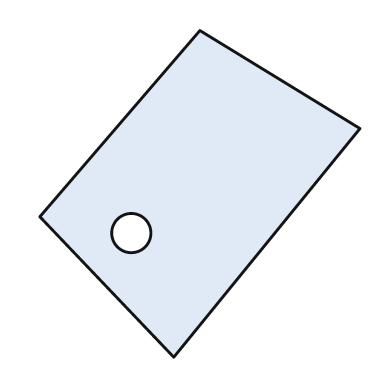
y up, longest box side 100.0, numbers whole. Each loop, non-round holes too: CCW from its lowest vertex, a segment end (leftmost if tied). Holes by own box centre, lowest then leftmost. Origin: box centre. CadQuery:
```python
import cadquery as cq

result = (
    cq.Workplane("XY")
    .moveTo(-8.0, -50.0)
    .lineTo(49.0, 20.0)
    .lineTo(0.0, 50.0)
    .lineTo(-49.0, -7.0)
    .close()
    .moveTo(-21.0, -12.0)
    .circle(6.0)
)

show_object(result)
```